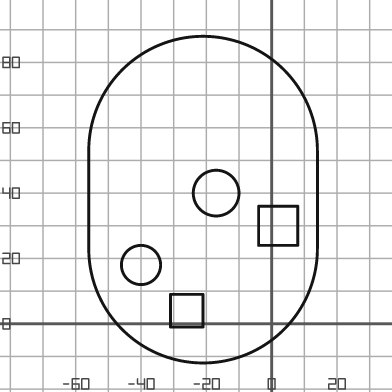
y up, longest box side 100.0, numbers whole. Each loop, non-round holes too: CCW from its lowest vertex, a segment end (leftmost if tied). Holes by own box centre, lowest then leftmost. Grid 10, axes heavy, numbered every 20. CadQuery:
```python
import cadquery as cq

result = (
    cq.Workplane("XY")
    .moveTo(-56.0, 23.0)
    .threePointArc((-21.0, -12.0), (14.0, 23.0))
    .lineTo(14.0, 53.0)
    .threePointArc((-21.0, 88.0), (-56.0, 53.0))
    .close()
    .moveTo(-31.0, -1.0)
    .lineTo(-21.0, -1.0)
    .lineTo(-21.0, 9.0)
    .lineTo(-31.0, 9.0)
    .close()
    .moveTo(-40.0, 18.0)
    .circle(6.0)
    .moveTo(-4.0, 24.0)
    .lineTo(8.0, 24.0)
    .lineTo(8.0, 36.0)
    .lineTo(-4.0, 36.0)
    .close()
    .moveTo(-17.0, 40.0)
    .circle(7.0)
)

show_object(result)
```